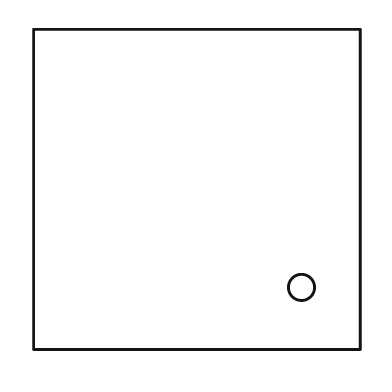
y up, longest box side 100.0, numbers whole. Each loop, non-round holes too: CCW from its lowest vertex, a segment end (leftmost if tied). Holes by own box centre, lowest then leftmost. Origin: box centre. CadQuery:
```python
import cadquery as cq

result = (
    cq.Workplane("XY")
    .moveTo(-50.0, -49.0)
    .lineTo(50.0, -49.0)
    .lineTo(50.0, 49.0)
    .lineTo(-50.0, 49.0)
    .close()
    .moveTo(32.0, -30.0)
    .circle(4.0)
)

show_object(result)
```